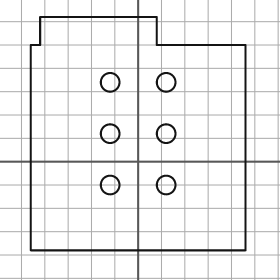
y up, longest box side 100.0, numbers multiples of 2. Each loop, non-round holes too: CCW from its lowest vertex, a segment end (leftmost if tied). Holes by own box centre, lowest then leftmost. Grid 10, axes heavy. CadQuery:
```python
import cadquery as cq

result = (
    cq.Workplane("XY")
    .moveTo(-46.0, -38.0)
    .lineTo(46.0, -38.0)
    .lineTo(46.0, 50.0)
    .lineTo(8.0, 50.0)
    .lineTo(8.0, 62.0)
    .lineTo(-42.0, 62.0)
    .lineTo(-42.0, 50.0)
    .lineTo(-46.0, 50.0)
    .close()
    .moveTo(-12.0, -10.0)
    .circle(4.0)
    .moveTo(12.0, -10.0)
    .circle(4.0)
    .moveTo(-12.0, 12.0)
    .circle(4.0)
    .moveTo(12.0, 12.0)
    .circle(4.0)
    .moveTo(-12.0, 34.0)
    .circle(4.0)
    .moveTo(12.0, 34.0)
    .circle(4.0)
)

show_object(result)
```